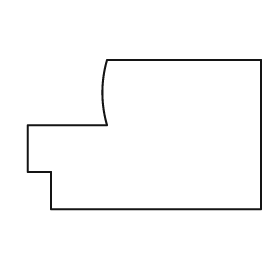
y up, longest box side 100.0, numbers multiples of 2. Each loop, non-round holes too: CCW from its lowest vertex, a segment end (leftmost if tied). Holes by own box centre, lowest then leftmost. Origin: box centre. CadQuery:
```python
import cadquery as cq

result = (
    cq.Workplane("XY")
    .moveTo(-40.0, -32.0)
    .lineTo(50.0, -32.0)
    .lineTo(50.0, 32.0)
    .lineTo(-16.0, 32.0)
    .threePointArc((-18.0, 18.0), (-16.0, 4.0))
    .lineTo(-50.0, 4.0)
    .lineTo(-50.0, -16.0)
    .lineTo(-40.0, -16.0)
    .close()
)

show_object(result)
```